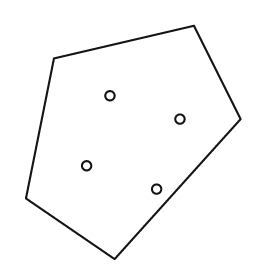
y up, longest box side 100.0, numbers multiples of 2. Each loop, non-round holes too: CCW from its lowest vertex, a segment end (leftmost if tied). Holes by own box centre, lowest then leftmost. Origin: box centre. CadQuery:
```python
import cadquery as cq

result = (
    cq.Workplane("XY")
    .moveTo(-8.0, -50.0)
    .lineTo(46.0, 10.0)
    .lineTo(26.0, 50.0)
    .lineTo(-34.0, 36.0)
    .lineTo(-46.0, -24.0)
    .close()
    .moveTo(10.0, -20.0)
    .circle(2.0)
    .moveTo(-20.0, -10.0)
    .circle(2.0)
    .moveTo(20.0, 10.0)
    .circle(2.0)
    .moveTo(-10.0, 20.0)
    .circle(2.0)
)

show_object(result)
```